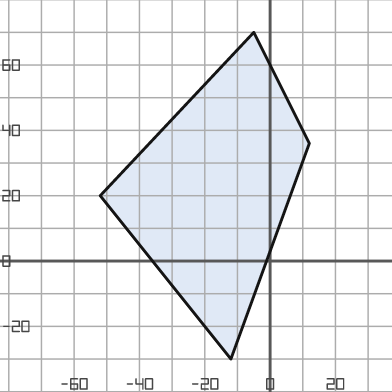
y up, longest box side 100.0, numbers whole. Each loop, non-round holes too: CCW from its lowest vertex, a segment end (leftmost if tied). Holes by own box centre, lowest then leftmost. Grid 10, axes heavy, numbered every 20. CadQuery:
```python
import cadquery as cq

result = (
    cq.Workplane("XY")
    .moveTo(-12.0, -30.0)
    .lineTo(12.0, 36.0)
    .lineTo(-5.0, 70.0)
    .lineTo(-52.0, 20.0)
    .close()
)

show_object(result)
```